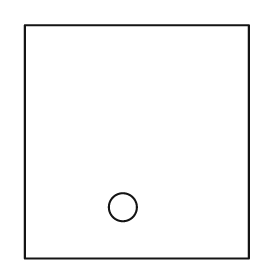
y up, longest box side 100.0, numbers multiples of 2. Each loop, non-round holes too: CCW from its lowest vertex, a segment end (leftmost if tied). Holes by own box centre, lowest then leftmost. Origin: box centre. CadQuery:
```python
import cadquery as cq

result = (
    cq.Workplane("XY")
    .moveTo(-48.0, -50.0)
    .lineTo(48.0, -50.0)
    .lineTo(48.0, 50.0)
    .lineTo(-48.0, 50.0)
    .close()
    .moveTo(-6.0, -28.0)
    .circle(6.0)
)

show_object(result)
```